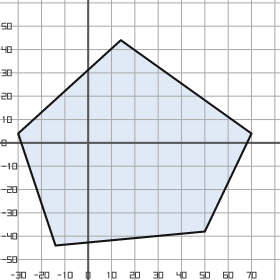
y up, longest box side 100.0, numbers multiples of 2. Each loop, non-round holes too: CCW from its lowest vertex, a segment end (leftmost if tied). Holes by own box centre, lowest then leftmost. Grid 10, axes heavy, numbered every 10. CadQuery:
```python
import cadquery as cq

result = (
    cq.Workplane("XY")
    .moveTo(-14.0, -44.0)
    .lineTo(50.0, -38.0)
    .lineTo(70.0, 4.0)
    .lineTo(14.0, 44.0)
    .lineTo(-30.0, 4.0)
    .close()
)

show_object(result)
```